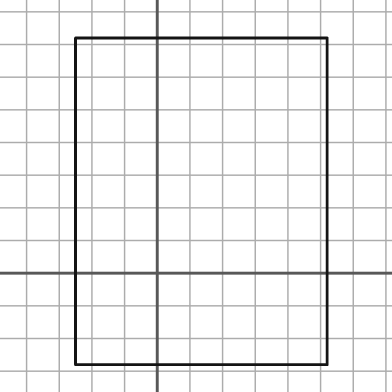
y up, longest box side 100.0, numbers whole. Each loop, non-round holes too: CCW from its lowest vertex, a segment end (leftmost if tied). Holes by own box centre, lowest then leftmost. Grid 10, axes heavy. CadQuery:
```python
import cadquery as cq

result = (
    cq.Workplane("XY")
    .moveTo(-25.0, -28.0)
    .lineTo(52.0, -28.0)
    .lineTo(52.0, 72.0)
    .lineTo(-25.0, 72.0)
    .close()
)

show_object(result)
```